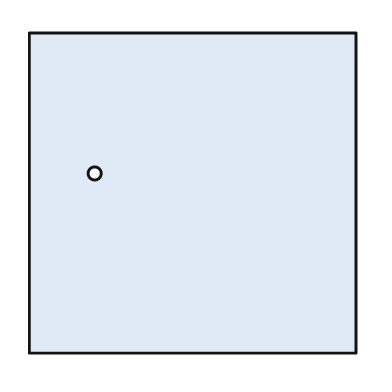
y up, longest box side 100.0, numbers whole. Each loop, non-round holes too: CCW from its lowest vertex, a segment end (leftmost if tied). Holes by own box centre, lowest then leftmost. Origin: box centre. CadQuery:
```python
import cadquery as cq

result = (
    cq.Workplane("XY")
    .moveTo(-50.0, -49.0)
    .lineTo(50.0, -49.0)
    .lineTo(50.0, 49.0)
    .lineTo(-50.0, 49.0)
    .close()
    .moveTo(-30.0, 6.0)
    .circle(2.0)
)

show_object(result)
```